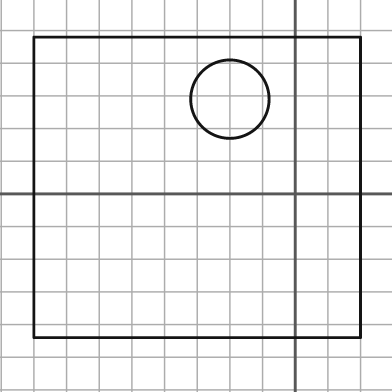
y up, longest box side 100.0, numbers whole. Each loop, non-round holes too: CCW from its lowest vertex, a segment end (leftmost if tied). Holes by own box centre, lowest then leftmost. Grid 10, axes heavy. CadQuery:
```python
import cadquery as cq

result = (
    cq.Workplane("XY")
    .moveTo(-80.0, -44.0)
    .lineTo(20.0, -44.0)
    .lineTo(20.0, 48.0)
    .lineTo(-80.0, 48.0)
    .close()
    .moveTo(-20.0, 29.0)
    .circle(12.0)
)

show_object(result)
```